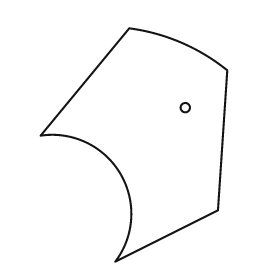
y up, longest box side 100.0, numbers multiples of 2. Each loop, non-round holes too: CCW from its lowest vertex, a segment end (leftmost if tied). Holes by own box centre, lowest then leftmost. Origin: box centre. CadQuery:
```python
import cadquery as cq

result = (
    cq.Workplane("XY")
    .moveTo(-8.0, -50.0)
    .lineTo(36.0, -28.0)
    .lineTo(40.0, 32.0)
    .threePointArc((20.0, 44.0), (-2.0, 50.0))
    .lineTo(-40.0, 4.0)
    .threePointArc((-6.0, -12.0), (-8.0, -50.0))
    .close()
    .moveTo(22.0, 16.0)
    .circle(2.0)
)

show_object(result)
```